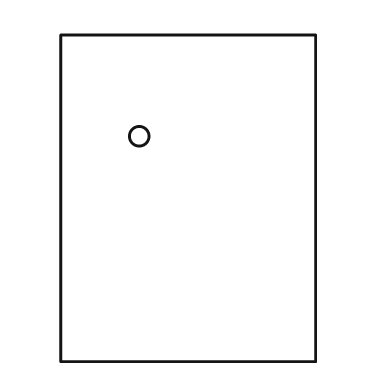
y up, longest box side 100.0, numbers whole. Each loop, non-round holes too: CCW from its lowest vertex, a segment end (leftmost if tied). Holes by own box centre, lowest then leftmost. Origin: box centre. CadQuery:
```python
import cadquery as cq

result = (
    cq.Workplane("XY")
    .moveTo(-39.0, -50.0)
    .lineTo(39.0, -50.0)
    .lineTo(39.0, 50.0)
    .lineTo(-39.0, 50.0)
    .close()
    .moveTo(-15.0, 19.0)
    .circle(3.0)
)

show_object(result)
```